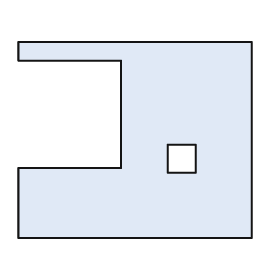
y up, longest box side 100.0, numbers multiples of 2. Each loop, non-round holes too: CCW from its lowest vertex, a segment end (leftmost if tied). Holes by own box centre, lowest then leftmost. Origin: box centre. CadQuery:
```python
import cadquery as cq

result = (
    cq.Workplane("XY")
    .moveTo(-50.0, -42.0)
    .lineTo(50.0, -42.0)
    .lineTo(50.0, 42.0)
    .lineTo(-50.0, 42.0)
    .lineTo(-50.0, 34.0)
    .lineTo(-6.0, 34.0)
    .lineTo(-6.0, -12.0)
    .lineTo(-50.0, -12.0)
    .close()
    .moveTo(14.0, -14.0)
    .lineTo(26.0, -14.0)
    .lineTo(26.0, -2.0)
    .lineTo(14.0, -2.0)
    .close()
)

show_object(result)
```